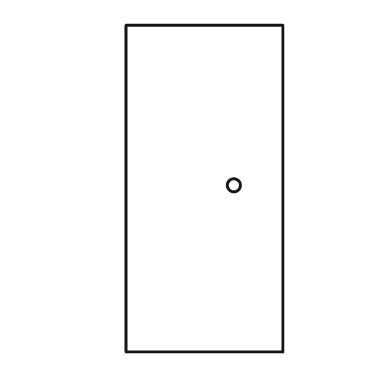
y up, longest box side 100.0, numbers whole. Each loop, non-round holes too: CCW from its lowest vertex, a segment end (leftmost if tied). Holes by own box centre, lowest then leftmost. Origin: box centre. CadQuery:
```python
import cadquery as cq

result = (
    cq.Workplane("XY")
    .moveTo(-24.0, -50.0)
    .lineTo(24.0, -50.0)
    .lineTo(24.0, 50.0)
    .lineTo(-24.0, 50.0)
    .close()
    .moveTo(9.0, 1.0)
    .circle(2.0)
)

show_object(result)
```